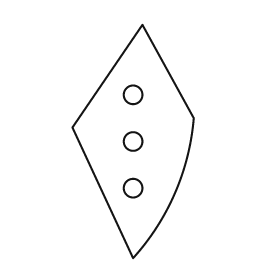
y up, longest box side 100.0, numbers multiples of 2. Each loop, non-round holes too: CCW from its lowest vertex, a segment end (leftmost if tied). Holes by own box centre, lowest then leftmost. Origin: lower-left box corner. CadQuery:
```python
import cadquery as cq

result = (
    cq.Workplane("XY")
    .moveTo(26.0, 0.0)
    .threePointArc((44.0, 28.0), (52.0, 60.0))
    .lineTo(30.0, 100.0)
    .lineTo(0.0, 56.0)
    .close()
    .moveTo(26.0, 30.0)
    .circle(4.0)
    .moveTo(26.0, 50.0)
    .circle(4.0)
    .moveTo(26.0, 70.0)
    .circle(4.0)
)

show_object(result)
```